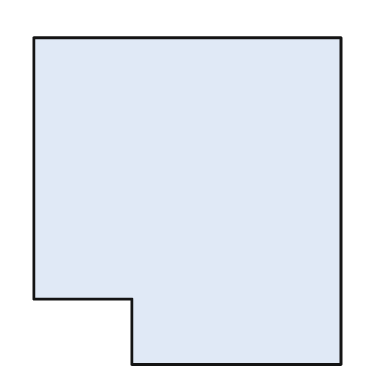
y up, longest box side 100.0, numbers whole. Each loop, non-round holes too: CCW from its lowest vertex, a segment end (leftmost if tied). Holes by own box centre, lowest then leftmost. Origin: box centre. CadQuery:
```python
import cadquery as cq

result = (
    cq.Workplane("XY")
    .moveTo(-17.0, -50.0)
    .lineTo(47.0, -50.0)
    .lineTo(47.0, 50.0)
    .lineTo(-47.0, 50.0)
    .lineTo(-47.0, -30.0)
    .lineTo(-17.0, -30.0)
    .close()
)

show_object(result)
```